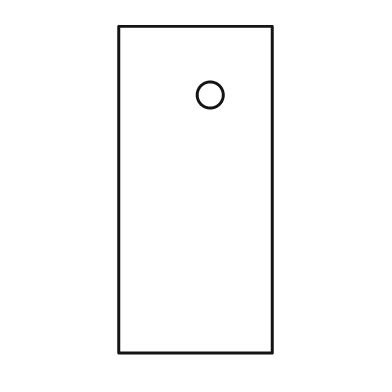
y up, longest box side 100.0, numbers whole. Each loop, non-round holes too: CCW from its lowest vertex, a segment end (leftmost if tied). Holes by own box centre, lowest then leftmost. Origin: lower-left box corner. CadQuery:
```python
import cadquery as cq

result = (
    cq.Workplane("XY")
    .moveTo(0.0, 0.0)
    .lineTo(47.0, 0.0)
    .lineTo(47.0, 100.0)
    .lineTo(0.0, 100.0)
    .close()
    .moveTo(28.0, 79.0)
    .circle(4.0)
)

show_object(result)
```